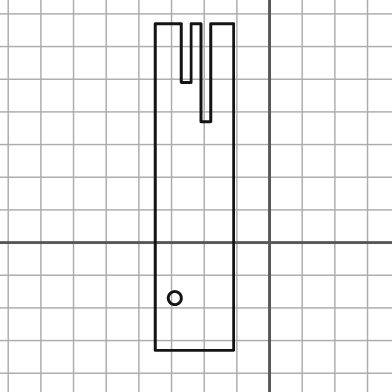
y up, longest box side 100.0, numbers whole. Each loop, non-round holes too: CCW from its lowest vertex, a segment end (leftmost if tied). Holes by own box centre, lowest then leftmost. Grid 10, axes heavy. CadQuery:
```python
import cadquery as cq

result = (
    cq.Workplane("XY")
    .moveTo(-35.0, -33.0)
    .lineTo(-11.0, -33.0)
    .lineTo(-11.0, 67.0)
    .lineTo(-18.0, 67.0)
    .lineTo(-18.0, 37.0)
    .lineTo(-21.0, 37.0)
    .lineTo(-21.0, 67.0)
    .lineTo(-24.0, 67.0)
    .lineTo(-24.0, 49.0)
    .lineTo(-27.0, 49.0)
    .lineTo(-27.0, 67.0)
    .lineTo(-35.0, 67.0)
    .close()
    .moveTo(-29.0, -17.0)
    .circle(2.0)
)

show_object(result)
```